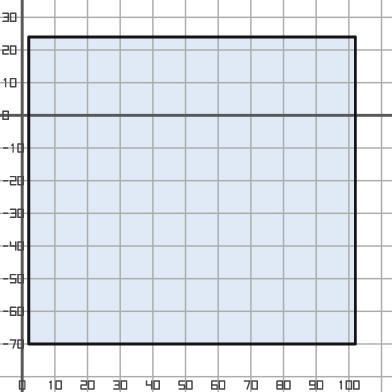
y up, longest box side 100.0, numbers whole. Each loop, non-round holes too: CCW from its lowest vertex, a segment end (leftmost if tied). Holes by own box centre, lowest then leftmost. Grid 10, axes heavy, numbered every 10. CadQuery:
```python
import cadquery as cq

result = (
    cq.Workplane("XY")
    .moveTo(2.0, -70.0)
    .lineTo(102.0, -70.0)
    .lineTo(102.0, 24.0)
    .lineTo(2.0, 24.0)
    .close()
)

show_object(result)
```